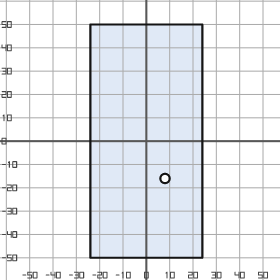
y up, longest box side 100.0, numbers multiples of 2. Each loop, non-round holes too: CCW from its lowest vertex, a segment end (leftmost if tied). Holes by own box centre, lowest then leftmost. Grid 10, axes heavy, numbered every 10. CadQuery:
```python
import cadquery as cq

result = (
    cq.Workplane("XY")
    .moveTo(-24.0, -50.0)
    .lineTo(24.0, -50.0)
    .lineTo(24.0, 50.0)
    .lineTo(-24.0, 50.0)
    .close()
    .moveTo(8.0, -16.0)
    .circle(2.0)
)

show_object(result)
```